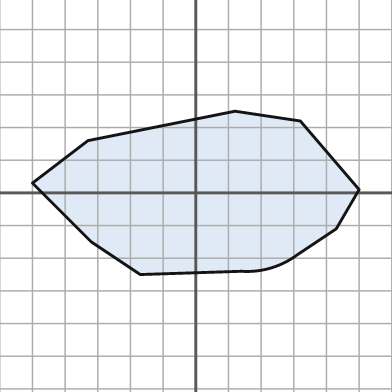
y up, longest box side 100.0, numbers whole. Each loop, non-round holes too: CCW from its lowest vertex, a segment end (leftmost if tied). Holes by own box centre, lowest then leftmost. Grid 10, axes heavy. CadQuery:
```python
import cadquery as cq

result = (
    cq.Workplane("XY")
    .moveTo(-17.0, -25.0)
    .lineTo(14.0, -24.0)
    .threePointArc((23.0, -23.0), (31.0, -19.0))
    .lineTo(43.0, -11.0)
    .lineTo(50.0, 1.0)
    .lineTo(32.0, 22.0)
    .lineTo(12.0, 25.0)
    .lineTo(-33.0, 16.0)
    .lineTo(-50.0, 3.0)
    .lineTo(-32.0, -15.0)
    .close()
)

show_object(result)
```